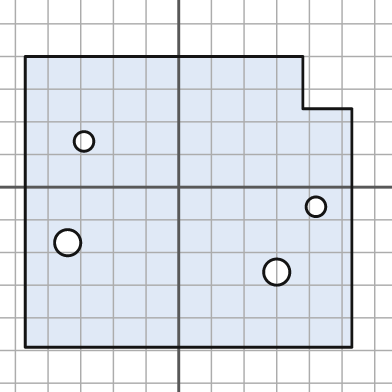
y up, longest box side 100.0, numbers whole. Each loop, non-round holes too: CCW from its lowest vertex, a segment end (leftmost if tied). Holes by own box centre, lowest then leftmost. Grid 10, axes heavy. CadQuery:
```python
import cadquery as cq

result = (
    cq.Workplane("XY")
    .moveTo(-47.0, -49.0)
    .lineTo(53.0, -49.0)
    .lineTo(53.0, 24.0)
    .lineTo(38.0, 24.0)
    .lineTo(38.0, 40.0)
    .lineTo(-47.0, 40.0)
    .close()
    .moveTo(30.0, -26.0)
    .circle(4.0)
    .moveTo(-34.0, -17.0)
    .circle(4.0)
    .moveTo(42.0, -6.0)
    .circle(3.0)
    .moveTo(-29.0, 14.0)
    .circle(3.0)
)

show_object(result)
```